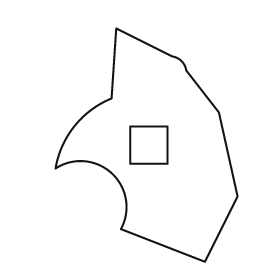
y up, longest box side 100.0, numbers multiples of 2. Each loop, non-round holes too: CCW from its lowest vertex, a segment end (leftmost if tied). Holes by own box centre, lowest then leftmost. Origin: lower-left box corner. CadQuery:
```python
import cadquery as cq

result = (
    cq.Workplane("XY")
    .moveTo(64.0, 0.0)
    .lineTo(78.0, 28.0)
    .lineTo(70.0, 64.0)
    .lineTo(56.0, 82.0)
    .threePointArc((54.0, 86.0), (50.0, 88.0))
    .lineTo(26.0, 100.0)
    .lineTo(24.0, 70.0)
    .threePointArc((8.0, 58.0), (0.0, 40.0))
    .threePointArc((24.0, 38.0), (28.0, 14.0))
    .close()
    .moveTo(32.0, 42.0)
    .lineTo(48.0, 42.0)
    .lineTo(48.0, 58.0)
    .lineTo(32.0, 58.0)
    .close()
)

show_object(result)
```